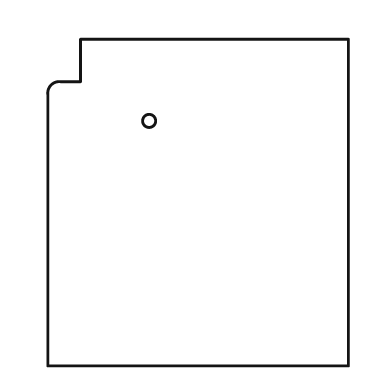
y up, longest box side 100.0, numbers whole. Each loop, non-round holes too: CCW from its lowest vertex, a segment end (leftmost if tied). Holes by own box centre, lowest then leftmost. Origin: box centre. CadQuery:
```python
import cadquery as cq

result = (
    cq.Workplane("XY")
    .moveTo(-46.0, -50.0)
    .lineTo(46.0, -50.0)
    .lineTo(46.0, 50.0)
    .lineTo(-36.0, 50.0)
    .lineTo(-36.0, 37.0)
    .lineTo(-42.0, 37.0)
    .threePointArc((-45.0, 36.0), (-46.0, 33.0))
    .close()
    .moveTo(-15.0, 25.0)
    .circle(2.0)
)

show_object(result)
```